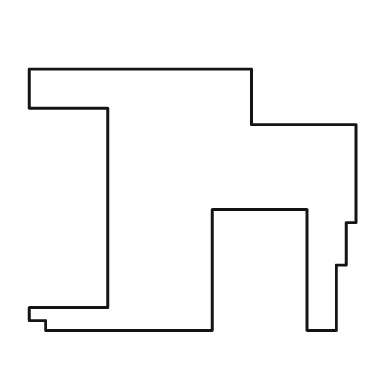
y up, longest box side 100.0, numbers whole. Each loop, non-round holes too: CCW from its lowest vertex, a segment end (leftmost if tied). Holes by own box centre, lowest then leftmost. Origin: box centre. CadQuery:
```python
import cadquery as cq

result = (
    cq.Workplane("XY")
    .moveTo(-45.0, -40.0)
    .lineTo(6.0, -40.0)
    .lineTo(6.0, -3.0)
    .lineTo(35.0, -3.0)
    .lineTo(35.0, -40.0)
    .lineTo(44.0, -40.0)
    .lineTo(44.0, -20.0)
    .lineTo(47.0, -20.0)
    .lineTo(47.0, -7.0)
    .lineTo(50.0, -7.0)
    .lineTo(50.0, 23.0)
    .lineTo(18.0, 23.0)
    .lineTo(18.0, 40.0)
    .lineTo(-50.0, 40.0)
    .lineTo(-50.0, 28.0)
    .lineTo(-26.0, 28.0)
    .lineTo(-26.0, -33.0)
    .lineTo(-50.0, -33.0)
    .lineTo(-50.0, -37.0)
    .lineTo(-45.0, -37.0)
    .close()
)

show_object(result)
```